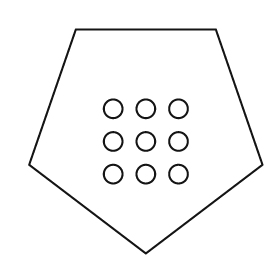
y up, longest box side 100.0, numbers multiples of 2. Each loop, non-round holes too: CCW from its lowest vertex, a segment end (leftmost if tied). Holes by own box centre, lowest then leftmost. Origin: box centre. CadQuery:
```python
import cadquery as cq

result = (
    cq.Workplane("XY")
    .moveTo(0.0, -48.0)
    .lineTo(50.0, -10.0)
    .lineTo(30.0, 48.0)
    .lineTo(-30.0, 48.0)
    .lineTo(-50.0, -10.0)
    .close()
    .moveTo(-14.0, -14.0)
    .circle(4.0)
    .moveTo(0.0, -14.0)
    .circle(4.0)
    .moveTo(14.0, -14.0)
    .circle(4.0)
    .moveTo(-14.0, 0.0)
    .circle(4.0)
    .moveTo(0.0, 0.0)
    .circle(4.0)
    .moveTo(14.0, 0.0)
    .circle(4.0)
    .moveTo(-14.0, 14.0)
    .circle(4.0)
    .moveTo(0.0, 14.0)
    .circle(4.0)
    .moveTo(14.0, 14.0)
    .circle(4.0)
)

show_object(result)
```